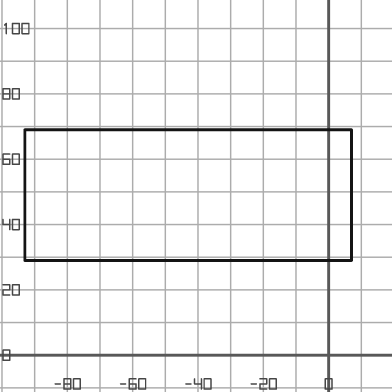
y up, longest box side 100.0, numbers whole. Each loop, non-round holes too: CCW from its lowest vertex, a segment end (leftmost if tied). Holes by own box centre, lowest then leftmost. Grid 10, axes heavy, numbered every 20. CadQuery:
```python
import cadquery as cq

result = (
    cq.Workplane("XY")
    .moveTo(-93.0, 29.0)
    .lineTo(7.0, 29.0)
    .lineTo(7.0, 69.0)
    .lineTo(-93.0, 69.0)
    .close()
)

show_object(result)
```